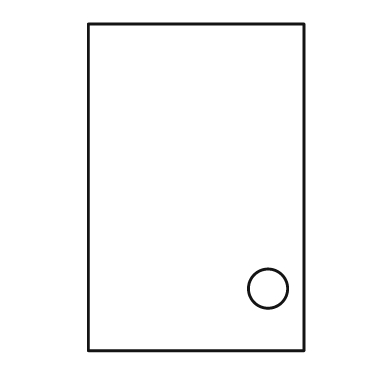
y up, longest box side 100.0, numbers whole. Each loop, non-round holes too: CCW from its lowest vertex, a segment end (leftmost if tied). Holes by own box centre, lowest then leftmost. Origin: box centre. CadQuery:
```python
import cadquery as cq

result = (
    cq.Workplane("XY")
    .moveTo(-33.0, -50.0)
    .lineTo(33.0, -50.0)
    .lineTo(33.0, 50.0)
    .lineTo(-33.0, 50.0)
    .close()
    .moveTo(22.0, -31.0)
    .circle(6.0)
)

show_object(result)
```